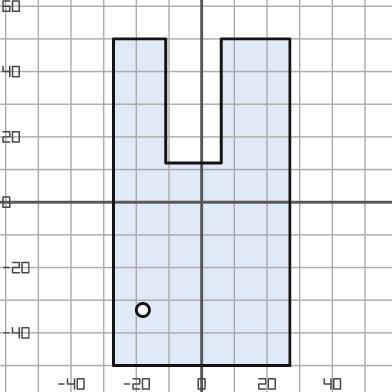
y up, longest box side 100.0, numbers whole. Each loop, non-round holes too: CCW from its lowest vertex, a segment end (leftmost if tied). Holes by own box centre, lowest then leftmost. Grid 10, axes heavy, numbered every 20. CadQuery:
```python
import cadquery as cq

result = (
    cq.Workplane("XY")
    .moveTo(-27.0, -50.0)
    .lineTo(27.0, -50.0)
    .lineTo(27.0, 50.0)
    .lineTo(6.0, 50.0)
    .lineTo(6.0, 12.0)
    .lineTo(-11.0, 12.0)
    .lineTo(-11.0, 50.0)
    .lineTo(-27.0, 50.0)
    .close()
    .moveTo(-18.0, -33.0)
    .circle(2.0)
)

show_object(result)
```